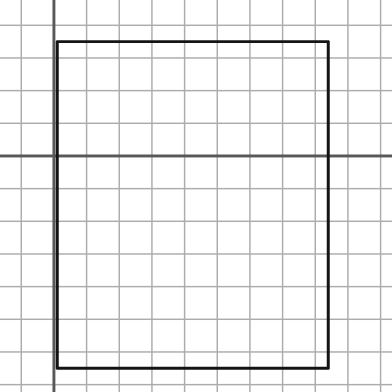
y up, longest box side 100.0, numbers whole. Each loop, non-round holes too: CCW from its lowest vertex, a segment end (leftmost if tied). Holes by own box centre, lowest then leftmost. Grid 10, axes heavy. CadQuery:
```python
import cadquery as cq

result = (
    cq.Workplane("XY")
    .moveTo(1.0, -65.0)
    .lineTo(84.0, -65.0)
    .lineTo(84.0, 35.0)
    .lineTo(1.0, 35.0)
    .close()
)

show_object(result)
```